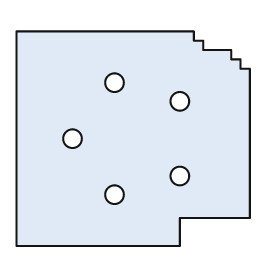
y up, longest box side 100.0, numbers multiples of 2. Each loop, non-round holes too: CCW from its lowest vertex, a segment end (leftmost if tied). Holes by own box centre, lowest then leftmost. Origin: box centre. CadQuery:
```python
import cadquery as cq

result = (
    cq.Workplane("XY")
    .moveTo(-50.0, -46.0)
    .lineTo(20.0, -46.0)
    .lineTo(20.0, -34.0)
    .lineTo(50.0, -34.0)
    .lineTo(50.0, 30.0)
    .lineTo(46.0, 30.0)
    .lineTo(46.0, 34.0)
    .lineTo(42.0, 34.0)
    .lineTo(42.0, 38.0)
    .lineTo(30.0, 38.0)
    .lineTo(30.0, 42.0)
    .lineTo(26.0, 42.0)
    .lineTo(26.0, 46.0)
    .lineTo(-50.0, 46.0)
    .close()
    .moveTo(-8.0, -24.0)
    .circle(4.0)
    .moveTo(20.0, -16.0)
    .circle(4.0)
    .moveTo(-26.0, 0.0)
    .circle(4.0)
    .moveTo(20.0, 16.0)
    .circle(4.0)
    .moveTo(-8.0, 24.0)
    .circle(4.0)
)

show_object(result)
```